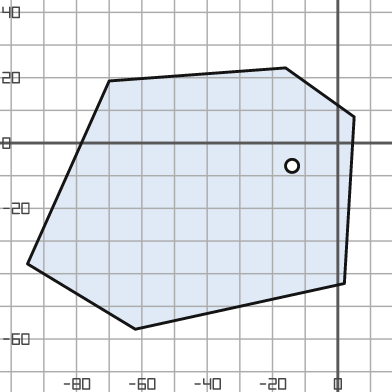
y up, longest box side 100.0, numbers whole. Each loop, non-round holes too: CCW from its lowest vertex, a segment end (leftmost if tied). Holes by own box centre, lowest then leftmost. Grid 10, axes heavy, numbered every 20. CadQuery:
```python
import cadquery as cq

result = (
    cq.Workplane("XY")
    .moveTo(-62.0, -57.0)
    .lineTo(2.0, -43.0)
    .lineTo(5.0, 8.0)
    .lineTo(-16.0, 23.0)
    .lineTo(-70.0, 19.0)
    .lineTo(-95.0, -37.0)
    .close()
    .moveTo(-14.0, -7.0)
    .circle(2.0)
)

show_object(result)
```